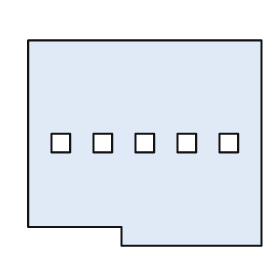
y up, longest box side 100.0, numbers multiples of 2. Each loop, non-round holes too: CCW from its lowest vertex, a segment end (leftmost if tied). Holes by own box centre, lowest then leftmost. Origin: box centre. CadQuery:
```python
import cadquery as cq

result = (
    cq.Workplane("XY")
    .moveTo(-10.0, -44.0)
    .lineTo(50.0, -44.0)
    .lineTo(50.0, 44.0)
    .lineTo(-50.0, 44.0)
    .lineTo(-50.0, -36.0)
    .lineTo(-10.0, -36.0)
    .close()
    .moveTo(-40.0, -4.0)
    .lineTo(-32.0, -4.0)
    .lineTo(-32.0, 4.0)
    .lineTo(-40.0, 4.0)
    .close()
    .moveTo(-22.0, -4.0)
    .lineTo(-14.0, -4.0)
    .lineTo(-14.0, 4.0)
    .lineTo(-22.0, 4.0)
    .close()
    .moveTo(-4.0, -4.0)
    .lineTo(4.0, -4.0)
    .lineTo(4.0, 4.0)
    .lineTo(-4.0, 4.0)
    .close()
    .moveTo(14.0, -4.0)
    .lineTo(22.0, -4.0)
    .lineTo(22.0, 4.0)
    .lineTo(14.0, 4.0)
    .close()
    .moveTo(32.0, -4.0)
    .lineTo(40.0, -4.0)
    .lineTo(40.0, 4.0)
    .lineTo(32.0, 4.0)
    .close()
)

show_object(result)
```